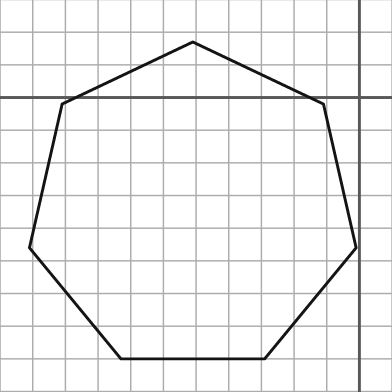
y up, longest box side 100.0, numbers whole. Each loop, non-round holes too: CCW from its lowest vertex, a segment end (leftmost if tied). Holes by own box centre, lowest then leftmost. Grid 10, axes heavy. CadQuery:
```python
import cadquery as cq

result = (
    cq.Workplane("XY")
    .moveTo(-73.0, -80.0)
    .lineTo(-29.0, -80.0)
    .lineTo(-1.0, -46.0)
    .lineTo(-11.0, -2.0)
    .lineTo(-51.0, 17.0)
    .lineTo(-91.0, -2.0)
    .lineTo(-101.0, -46.0)
    .close()
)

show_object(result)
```